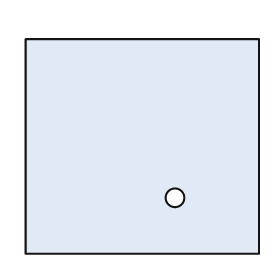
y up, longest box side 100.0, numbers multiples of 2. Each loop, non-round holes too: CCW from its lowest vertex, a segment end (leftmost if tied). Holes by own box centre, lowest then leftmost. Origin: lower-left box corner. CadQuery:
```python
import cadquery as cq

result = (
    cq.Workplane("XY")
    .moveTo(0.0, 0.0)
    .lineTo(100.0, 0.0)
    .lineTo(100.0, 92.0)
    .lineTo(0.0, 92.0)
    .close()
    .moveTo(64.0, 24.0)
    .circle(4.0)
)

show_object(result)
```